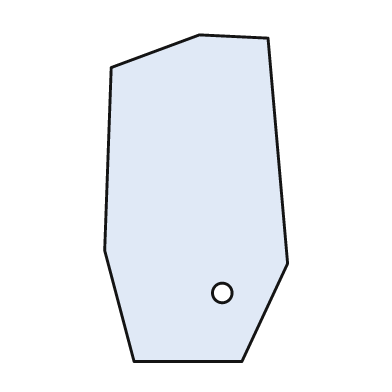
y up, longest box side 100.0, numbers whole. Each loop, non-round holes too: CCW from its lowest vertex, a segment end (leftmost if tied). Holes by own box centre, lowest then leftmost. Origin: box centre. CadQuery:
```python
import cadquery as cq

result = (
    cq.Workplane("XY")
    .moveTo(-19.0, -50.0)
    .lineTo(14.0, -50.0)
    .lineTo(28.0, -20.0)
    .lineTo(22.0, 49.0)
    .lineTo(1.0, 50.0)
    .lineTo(-26.0, 40.0)
    .lineTo(-28.0, -16.0)
    .close()
    .moveTo(8.0, -29.0)
    .circle(3.0)
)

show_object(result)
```